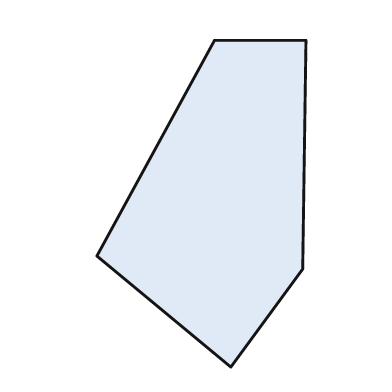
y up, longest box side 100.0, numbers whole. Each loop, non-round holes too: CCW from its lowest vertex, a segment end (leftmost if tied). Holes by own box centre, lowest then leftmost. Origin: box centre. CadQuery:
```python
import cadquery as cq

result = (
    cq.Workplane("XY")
    .moveTo(9.0, -50.0)
    .lineTo(31.0, -20.0)
    .lineTo(32.0, 50.0)
    .lineTo(4.0, 50.0)
    .lineTo(-32.0, -16.0)
    .close()
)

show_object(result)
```